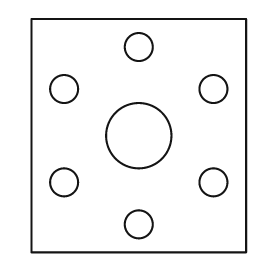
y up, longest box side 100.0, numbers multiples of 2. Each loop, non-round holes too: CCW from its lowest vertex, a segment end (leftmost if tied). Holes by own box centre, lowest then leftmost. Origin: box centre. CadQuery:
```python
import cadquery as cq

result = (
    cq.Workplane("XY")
    .moveTo(-46.0, -50.0)
    .lineTo(46.0, -50.0)
    .lineTo(46.0, 50.0)
    .lineTo(-46.0, 50.0)
    .close()
    .moveTo(0.0, -38.0)
    .circle(6.0)
    .moveTo(-32.0, -20.0)
    .circle(6.0)
    .moveTo(32.0, -20.0)
    .circle(6.0)
    .moveTo(0.0, 0.0)
    .circle(14.0)
    .moveTo(-32.0, 20.0)
    .circle(6.0)
    .moveTo(32.0, 20.0)
    .circle(6.0)
    .moveTo(0.0, 38.0)
    .circle(6.0)
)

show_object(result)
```